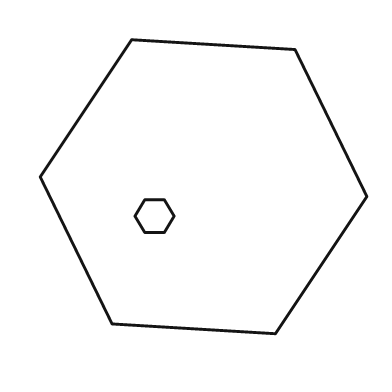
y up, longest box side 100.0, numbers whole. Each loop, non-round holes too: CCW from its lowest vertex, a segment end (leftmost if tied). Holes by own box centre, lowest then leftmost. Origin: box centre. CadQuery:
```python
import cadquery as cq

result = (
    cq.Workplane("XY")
    .moveTo(22.0, -45.0)
    .lineTo(50.0, -3.0)
    .lineTo(28.0, 42.0)
    .lineTo(-22.0, 45.0)
    .lineTo(-50.0, 3.0)
    .lineTo(-28.0, -42.0)
    .close()
    .moveTo(-18.0, -14.0)
    .lineTo(-12.0, -14.0)
    .lineTo(-9.0, -9.0)
    .lineTo(-12.0, -4.0)
    .lineTo(-18.0, -4.0)
    .lineTo(-21.0, -9.0)
    .close()
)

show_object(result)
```